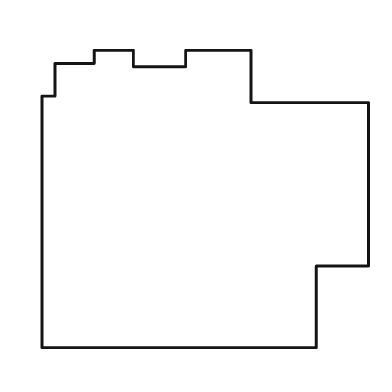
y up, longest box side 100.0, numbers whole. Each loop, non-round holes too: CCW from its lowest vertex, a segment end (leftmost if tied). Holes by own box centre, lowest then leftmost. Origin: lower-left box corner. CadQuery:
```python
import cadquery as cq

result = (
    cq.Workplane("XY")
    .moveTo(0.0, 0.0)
    .lineTo(84.0, 0.0)
    .lineTo(84.0, 25.0)
    .lineTo(100.0, 25.0)
    .lineTo(100.0, 75.0)
    .lineTo(64.0, 75.0)
    .lineTo(64.0, 91.0)
    .lineTo(44.0, 91.0)
    .lineTo(44.0, 86.0)
    .lineTo(28.0, 86.0)
    .lineTo(28.0, 91.0)
    .lineTo(16.0, 91.0)
    .lineTo(16.0, 87.0)
    .lineTo(4.0, 87.0)
    .lineTo(4.0, 77.0)
    .lineTo(0.0, 77.0)
    .close()
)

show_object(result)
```